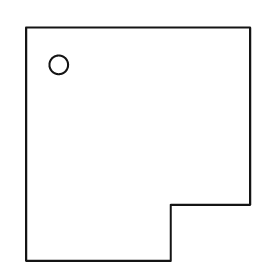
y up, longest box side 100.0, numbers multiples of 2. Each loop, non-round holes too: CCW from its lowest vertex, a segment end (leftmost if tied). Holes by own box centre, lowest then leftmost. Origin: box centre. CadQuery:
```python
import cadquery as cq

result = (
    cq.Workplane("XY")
    .moveTo(-48.0, -50.0)
    .lineTo(14.0, -50.0)
    .lineTo(14.0, -26.0)
    .lineTo(48.0, -26.0)
    .lineTo(48.0, 50.0)
    .lineTo(-48.0, 50.0)
    .close()
    .moveTo(-34.0, 34.0)
    .circle(4.0)
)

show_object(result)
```